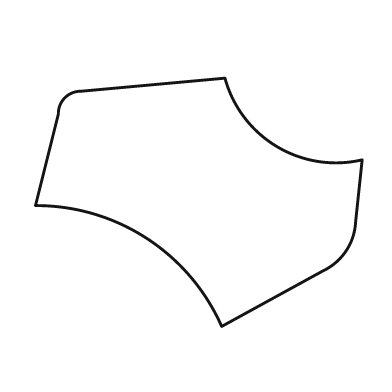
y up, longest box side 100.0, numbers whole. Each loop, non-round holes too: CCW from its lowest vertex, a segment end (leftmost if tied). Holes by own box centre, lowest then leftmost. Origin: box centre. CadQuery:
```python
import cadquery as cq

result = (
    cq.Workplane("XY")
    .moveTo(7.0, -38.0)
    .lineTo(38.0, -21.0)
    .threePointArc((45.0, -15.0), (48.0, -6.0))
    .lineTo(50.0, 13.0)
    .threePointArc((24.0, 17.0), (8.0, 38.0))
    .lineTo(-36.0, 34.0)
    .threePointArc((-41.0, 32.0), (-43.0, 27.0))
    .lineTo(-50.0, -1.0)
    .threePointArc((-16.0, -11.0), (7.0, -38.0))
    .close()
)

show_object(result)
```